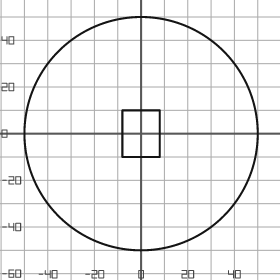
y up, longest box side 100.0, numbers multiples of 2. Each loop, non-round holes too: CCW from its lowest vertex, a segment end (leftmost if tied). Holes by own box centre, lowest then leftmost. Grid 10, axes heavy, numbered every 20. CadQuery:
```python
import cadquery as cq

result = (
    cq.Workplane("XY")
    .moveTo(0.0, 0.0)
    .circle(50.0)
    .moveTo(-8.0, -10.0)
    .lineTo(8.0, -10.0)
    .lineTo(8.0, 10.0)
    .lineTo(-8.0, 10.0)
    .close()
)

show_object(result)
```